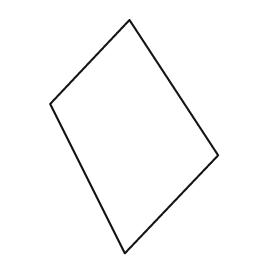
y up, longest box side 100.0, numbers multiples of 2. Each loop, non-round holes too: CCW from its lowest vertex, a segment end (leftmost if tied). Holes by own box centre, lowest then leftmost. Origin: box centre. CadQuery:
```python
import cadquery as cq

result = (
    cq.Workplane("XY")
    .moveTo(-4.0, -50.0)
    .lineTo(36.0, -8.0)
    .lineTo(-2.0, 50.0)
    .lineTo(-36.0, 14.0)
    .close()
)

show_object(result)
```